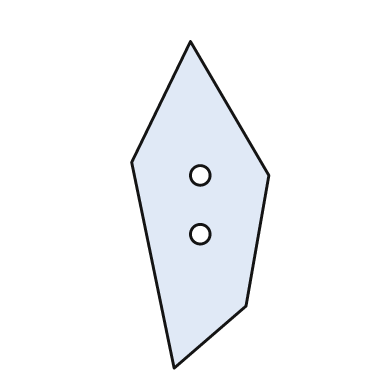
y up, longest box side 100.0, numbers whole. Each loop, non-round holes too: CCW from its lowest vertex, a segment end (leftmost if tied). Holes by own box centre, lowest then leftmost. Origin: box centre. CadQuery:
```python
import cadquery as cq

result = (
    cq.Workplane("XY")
    .moveTo(-8.0, -50.0)
    .lineTo(14.0, -31.0)
    .lineTo(21.0, 9.0)
    .lineTo(-3.0, 50.0)
    .lineTo(-21.0, 13.0)
    .close()
    .moveTo(0.0, -9.0)
    .circle(3.0)
    .moveTo(0.0, 9.0)
    .circle(3.0)
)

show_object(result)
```